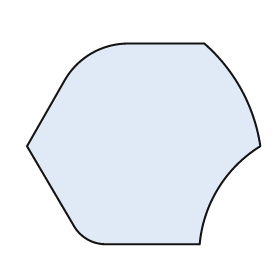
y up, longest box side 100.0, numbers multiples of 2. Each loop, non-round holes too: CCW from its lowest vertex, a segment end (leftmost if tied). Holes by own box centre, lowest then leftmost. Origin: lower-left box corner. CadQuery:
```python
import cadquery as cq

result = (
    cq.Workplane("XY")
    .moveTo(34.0, 0.0)
    .lineTo(74.0, 0.0)
    .threePointArc((82.0, 24.0), (100.0, 42.0))
    .threePointArc((92.0, 66.0), (76.0, 86.0))
    .lineTo(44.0, 86.0)
    .threePointArc((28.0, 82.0), (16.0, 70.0))
    .lineTo(0.0, 42.0)
    .lineTo(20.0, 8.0)
    .threePointArc((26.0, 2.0), (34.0, 0.0))
    .close()
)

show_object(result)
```